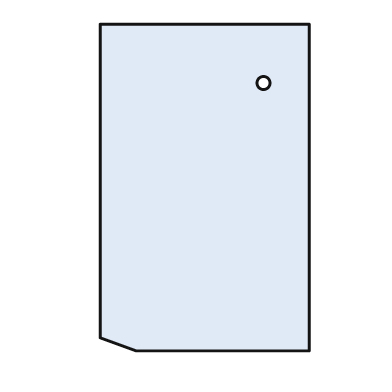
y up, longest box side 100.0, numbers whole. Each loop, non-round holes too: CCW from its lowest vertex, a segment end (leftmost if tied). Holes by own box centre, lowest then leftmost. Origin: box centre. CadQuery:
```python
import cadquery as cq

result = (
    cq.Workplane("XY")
    .moveTo(-21.0, -50.0)
    .lineTo(32.0, -50.0)
    .lineTo(32.0, 50.0)
    .lineTo(-32.0, 50.0)
    .lineTo(-32.0, -46.0)
    .close()
    .moveTo(18.0, 32.0)
    .circle(2.0)
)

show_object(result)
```